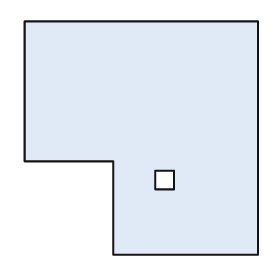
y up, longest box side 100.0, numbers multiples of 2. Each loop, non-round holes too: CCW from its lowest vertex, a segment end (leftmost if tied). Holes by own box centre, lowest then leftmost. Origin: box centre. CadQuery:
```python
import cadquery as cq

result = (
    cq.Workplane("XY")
    .moveTo(-12.0, -50.0)
    .lineTo(50.0, -50.0)
    .lineTo(50.0, 50.0)
    .lineTo(-50.0, 50.0)
    .lineTo(-50.0, -10.0)
    .lineTo(-12.0, -10.0)
    .close()
    .moveTo(6.0, -22.0)
    .lineTo(14.0, -22.0)
    .lineTo(14.0, -14.0)
    .lineTo(6.0, -14.0)
    .close()
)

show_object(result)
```